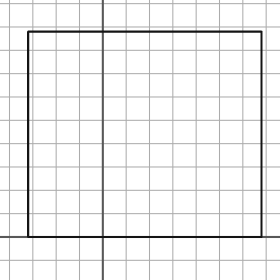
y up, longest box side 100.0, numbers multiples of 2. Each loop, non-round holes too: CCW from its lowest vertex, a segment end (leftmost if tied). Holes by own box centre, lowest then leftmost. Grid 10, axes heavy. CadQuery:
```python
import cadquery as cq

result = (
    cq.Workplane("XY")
    .moveTo(-32.0, 0.0)
    .lineTo(68.0, 0.0)
    .lineTo(68.0, 88.0)
    .lineTo(-32.0, 88.0)
    .close()
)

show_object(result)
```